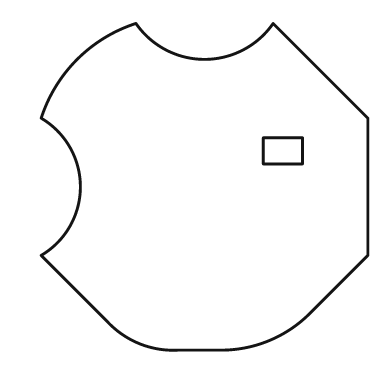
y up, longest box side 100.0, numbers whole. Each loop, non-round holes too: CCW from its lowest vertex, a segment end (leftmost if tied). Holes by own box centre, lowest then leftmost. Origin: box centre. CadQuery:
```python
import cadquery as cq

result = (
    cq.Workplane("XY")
    .moveTo(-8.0, -50.0)
    .lineTo(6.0, -50.0)
    .threePointArc((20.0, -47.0), (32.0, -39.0))
    .lineTo(50.0, -21.0)
    .lineTo(50.0, 21.0)
    .lineTo(21.0, 50.0)
    .threePointArc((0.0, 39.0), (-21.0, 50.0))
    .threePointArc((-39.0, 39.0), (-50.0, 21.0))
    .threePointArc((-38.0, 0.0), (-50.0, -21.0))
    .lineTo(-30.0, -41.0)
    .threePointArc((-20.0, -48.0), (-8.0, -50.0))
    .close()
    .moveTo(18.0, 7.0)
    .lineTo(30.0, 7.0)
    .lineTo(30.0, 15.0)
    .lineTo(18.0, 15.0)
    .close()
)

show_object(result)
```